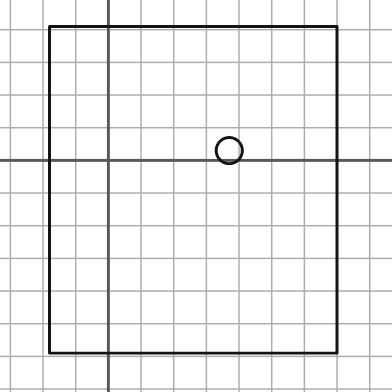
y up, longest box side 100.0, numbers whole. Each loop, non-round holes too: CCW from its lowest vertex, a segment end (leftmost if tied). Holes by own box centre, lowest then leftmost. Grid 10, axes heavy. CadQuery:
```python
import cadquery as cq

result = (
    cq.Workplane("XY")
    .moveTo(-18.0, -59.0)
    .lineTo(70.0, -59.0)
    .lineTo(70.0, 41.0)
    .lineTo(-18.0, 41.0)
    .close()
    .moveTo(37.0, 3.0)
    .circle(4.0)
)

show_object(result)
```